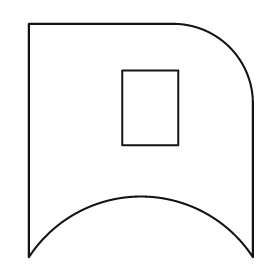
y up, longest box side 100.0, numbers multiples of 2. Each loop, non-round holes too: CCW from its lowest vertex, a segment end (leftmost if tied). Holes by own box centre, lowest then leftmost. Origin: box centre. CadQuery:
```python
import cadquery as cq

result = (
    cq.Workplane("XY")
    .moveTo(-48.0, -50.0)
    .threePointArc((0.0, -24.0), (48.0, -50.0))
    .lineTo(48.0, 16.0)
    .threePointArc((38.0, 40.0), (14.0, 50.0))
    .lineTo(-48.0, 50.0)
    .close()
    .moveTo(-8.0, -2.0)
    .lineTo(16.0, -2.0)
    .lineTo(16.0, 30.0)
    .lineTo(-8.0, 30.0)
    .close()
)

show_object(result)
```